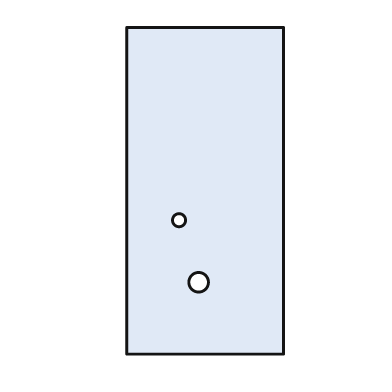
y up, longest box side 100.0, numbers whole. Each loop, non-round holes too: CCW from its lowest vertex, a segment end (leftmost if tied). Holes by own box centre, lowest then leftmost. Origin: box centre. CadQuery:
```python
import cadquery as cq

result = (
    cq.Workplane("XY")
    .moveTo(-24.0, -50.0)
    .lineTo(24.0, -50.0)
    .lineTo(24.0, 50.0)
    .lineTo(-24.0, 50.0)
    .close()
    .moveTo(-2.0, -28.0)
    .circle(3.0)
    .moveTo(-8.0, -9.0)
    .circle(2.0)
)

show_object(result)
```